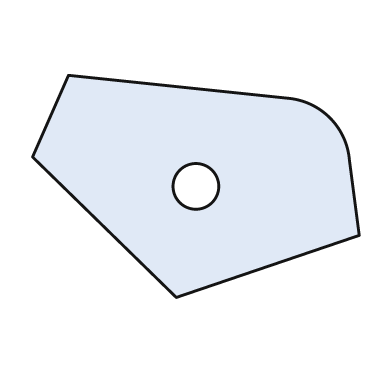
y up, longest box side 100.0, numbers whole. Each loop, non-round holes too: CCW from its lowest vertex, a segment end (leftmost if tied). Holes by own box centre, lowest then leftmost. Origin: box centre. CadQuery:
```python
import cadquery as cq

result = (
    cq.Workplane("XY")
    .moveTo(-6.0, -34.0)
    .lineTo(50.0, -15.0)
    .lineTo(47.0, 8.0)
    .threePointArc((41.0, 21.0), (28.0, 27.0))
    .lineTo(-39.0, 34.0)
    .lineTo(-50.0, 9.0)
    .close()
    .moveTo(0.0, 0.0)
    .circle(7.0)
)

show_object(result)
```